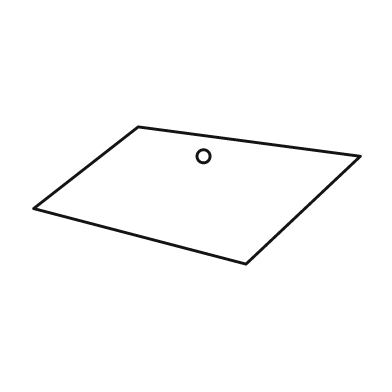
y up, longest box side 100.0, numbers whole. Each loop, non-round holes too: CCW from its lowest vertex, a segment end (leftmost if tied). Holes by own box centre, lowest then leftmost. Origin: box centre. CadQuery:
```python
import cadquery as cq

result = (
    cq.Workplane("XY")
    .moveTo(15.0, -21.0)
    .lineTo(50.0, 12.0)
    .lineTo(-18.0, 21.0)
    .lineTo(-50.0, -4.0)
    .close()
    .moveTo(2.0, 12.0)
    .circle(2.0)
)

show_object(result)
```